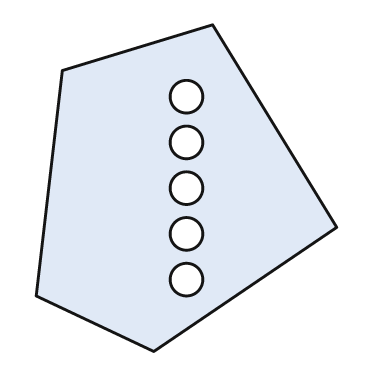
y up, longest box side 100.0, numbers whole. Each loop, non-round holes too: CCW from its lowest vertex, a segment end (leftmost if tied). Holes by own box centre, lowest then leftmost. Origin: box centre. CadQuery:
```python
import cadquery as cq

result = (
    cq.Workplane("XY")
    .moveTo(-10.0, -50.0)
    .lineTo(46.0, -12.0)
    .lineTo(8.0, 50.0)
    .lineTo(-38.0, 36.0)
    .lineTo(-46.0, -33.0)
    .close()
    .moveTo(0.0, -28.0)
    .circle(5.0)
    .moveTo(0.0, -14.0)
    .circle(5.0)
    .moveTo(0.0, 0.0)
    .circle(5.0)
    .moveTo(0.0, 14.0)
    .circle(5.0)
    .moveTo(0.0, 28.0)
    .circle(5.0)
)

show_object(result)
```